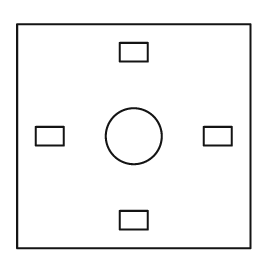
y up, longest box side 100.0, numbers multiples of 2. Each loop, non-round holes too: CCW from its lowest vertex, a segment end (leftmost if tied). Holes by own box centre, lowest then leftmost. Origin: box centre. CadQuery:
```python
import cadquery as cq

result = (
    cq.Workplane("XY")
    .moveTo(-50.0, -48.0)
    .lineTo(50.0, -48.0)
    .lineTo(50.0, 48.0)
    .lineTo(-50.0, 48.0)
    .close()
    .moveTo(-6.0, -40.0)
    .lineTo(6.0, -40.0)
    .lineTo(6.0, -32.0)
    .lineTo(-6.0, -32.0)
    .close()
    .moveTo(-42.0, -4.0)
    .lineTo(-30.0, -4.0)
    .lineTo(-30.0, 4.0)
    .lineTo(-42.0, 4.0)
    .close()
    .moveTo(0.0, 0.0)
    .circle(12.0)
    .moveTo(30.0, -4.0)
    .lineTo(42.0, -4.0)
    .lineTo(42.0, 4.0)
    .lineTo(30.0, 4.0)
    .close()
    .moveTo(-6.0, 32.0)
    .lineTo(6.0, 32.0)
    .lineTo(6.0, 40.0)
    .lineTo(-6.0, 40.0)
    .close()
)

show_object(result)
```